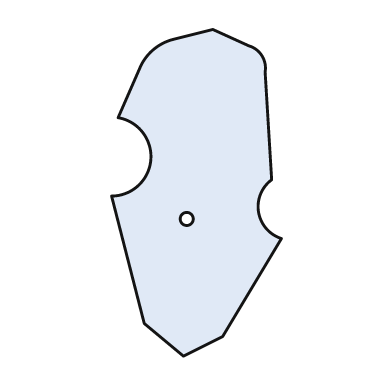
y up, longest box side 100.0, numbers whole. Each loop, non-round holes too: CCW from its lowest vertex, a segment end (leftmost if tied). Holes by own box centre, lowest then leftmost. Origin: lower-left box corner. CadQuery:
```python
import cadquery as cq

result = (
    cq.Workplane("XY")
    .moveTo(22.0, 0.0)
    .lineTo(34.0, 6.0)
    .lineTo(52.0, 36.0)
    .threePointArc((45.0, 44.0), (49.0, 54.0))
    .lineTo(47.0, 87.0)
    .threePointArc((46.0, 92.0), (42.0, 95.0))
    .lineTo(31.0, 100.0)
    .lineTo(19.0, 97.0)
    .threePointArc((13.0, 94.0), (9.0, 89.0))
    .lineTo(2.0, 73.0)
    .threePointArc((12.0, 60.0), (0.0, 49.0))
    .lineTo(10.0, 10.0)
    .close()
    .moveTo(23.0, 42.0)
    .circle(2.0)
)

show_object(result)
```